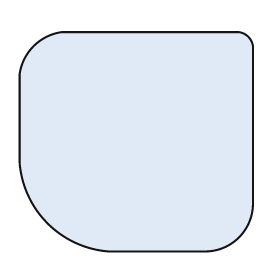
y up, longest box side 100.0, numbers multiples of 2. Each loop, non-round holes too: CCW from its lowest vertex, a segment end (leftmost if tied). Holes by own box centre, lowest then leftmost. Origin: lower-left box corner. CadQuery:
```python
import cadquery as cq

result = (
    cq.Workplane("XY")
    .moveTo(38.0, 0.0)
    .lineTo(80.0, 0.0)
    .threePointArc((94.0, 6.0), (100.0, 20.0))
    .lineTo(100.0, 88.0)
    .threePointArc((98.0, 92.0), (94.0, 94.0))
    .lineTo(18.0, 94.0)
    .threePointArc((6.0, 88.0), (0.0, 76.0))
    .lineTo(0.0, 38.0)
    .threePointArc((12.0, 12.0), (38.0, 0.0))
    .close()
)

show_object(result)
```